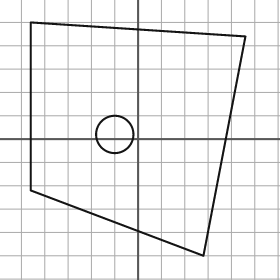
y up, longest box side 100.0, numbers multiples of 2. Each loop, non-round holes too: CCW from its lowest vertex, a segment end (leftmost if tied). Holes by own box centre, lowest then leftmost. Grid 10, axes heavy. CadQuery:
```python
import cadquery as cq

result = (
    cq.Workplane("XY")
    .moveTo(28.0, -50.0)
    .lineTo(46.0, 44.0)
    .lineTo(-46.0, 50.0)
    .lineTo(-46.0, -22.0)
    .close()
    .moveTo(-10.0, 2.0)
    .circle(8.0)
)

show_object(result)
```